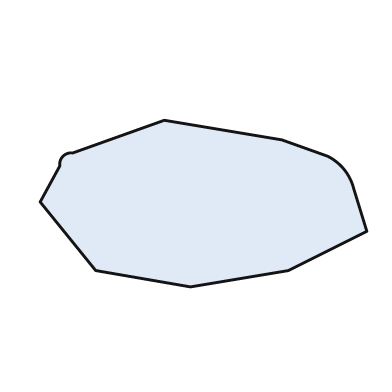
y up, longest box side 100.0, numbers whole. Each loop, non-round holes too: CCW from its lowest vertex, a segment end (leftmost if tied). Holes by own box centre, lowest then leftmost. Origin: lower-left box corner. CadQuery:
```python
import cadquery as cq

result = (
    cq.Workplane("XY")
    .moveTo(46.0, 0.0)
    .lineTo(76.0, 5.0)
    .lineTo(100.0, 17.0)
    .lineTo(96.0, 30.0)
    .threePointArc((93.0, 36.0), (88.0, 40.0))
    .lineTo(74.0, 45.0)
    .lineTo(38.0, 51.0)
    .lineTo(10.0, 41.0)
    .threePointArc((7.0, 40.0), (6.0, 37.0))
    .lineTo(0.0, 26.0)
    .lineTo(17.0, 5.0)
    .close()
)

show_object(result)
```